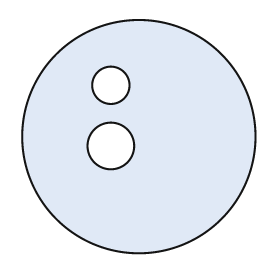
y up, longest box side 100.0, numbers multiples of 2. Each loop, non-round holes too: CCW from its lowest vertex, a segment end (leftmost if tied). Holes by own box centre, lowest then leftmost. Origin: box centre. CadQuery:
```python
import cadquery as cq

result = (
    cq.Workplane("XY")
    .moveTo(0.0, 0.0)
    .circle(50.0)
    .moveTo(-12.0, -4.0)
    .circle(10.0)
    .moveTo(-12.0, 22.0)
    .circle(8.0)
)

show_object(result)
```